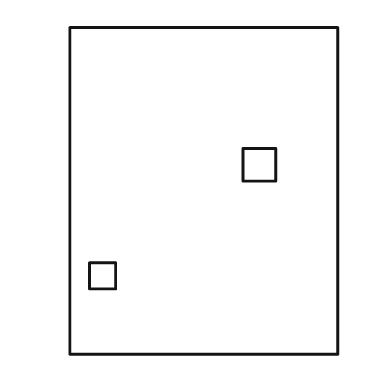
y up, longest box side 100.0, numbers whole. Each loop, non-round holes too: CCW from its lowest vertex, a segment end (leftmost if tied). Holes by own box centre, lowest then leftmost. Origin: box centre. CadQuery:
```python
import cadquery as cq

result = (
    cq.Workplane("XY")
    .moveTo(-41.0, -50.0)
    .lineTo(41.0, -50.0)
    .lineTo(41.0, 50.0)
    .lineTo(-41.0, 50.0)
    .close()
    .moveTo(-35.0, -30.0)
    .lineTo(-27.0, -30.0)
    .lineTo(-27.0, -22.0)
    .lineTo(-35.0, -22.0)
    .close()
    .moveTo(12.0, 3.0)
    .lineTo(22.0, 3.0)
    .lineTo(22.0, 13.0)
    .lineTo(12.0, 13.0)
    .close()
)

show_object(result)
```